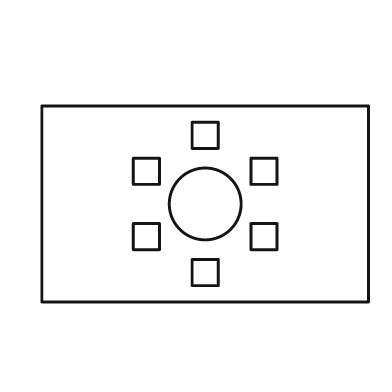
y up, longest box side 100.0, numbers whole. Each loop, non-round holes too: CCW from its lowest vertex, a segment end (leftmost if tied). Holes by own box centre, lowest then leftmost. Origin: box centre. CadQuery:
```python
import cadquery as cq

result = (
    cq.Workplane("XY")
    .moveTo(-50.0, -30.0)
    .lineTo(50.0, -30.0)
    .lineTo(50.0, 30.0)
    .lineTo(-50.0, 30.0)
    .close()
    .moveTo(-4.0, -25.0)
    .lineTo(4.0, -25.0)
    .lineTo(4.0, -17.0)
    .lineTo(-4.0, -17.0)
    .close()
    .moveTo(-22.0, -14.0)
    .lineTo(-14.0, -14.0)
    .lineTo(-14.0, -6.0)
    .lineTo(-22.0, -6.0)
    .close()
    .moveTo(14.0, -14.0)
    .lineTo(22.0, -14.0)
    .lineTo(22.0, -6.0)
    .lineTo(14.0, -6.0)
    .close()
    .moveTo(0.0, 0.0)
    .circle(11.0)
    .moveTo(-22.0, 6.0)
    .lineTo(-14.0, 6.0)
    .lineTo(-14.0, 14.0)
    .lineTo(-22.0, 14.0)
    .close()
    .moveTo(14.0, 6.0)
    .lineTo(22.0, 6.0)
    .lineTo(22.0, 14.0)
    .lineTo(14.0, 14.0)
    .close()
    .moveTo(-4.0, 17.0)
    .lineTo(4.0, 17.0)
    .lineTo(4.0, 25.0)
    .lineTo(-4.0, 25.0)
    .close()
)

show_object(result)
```